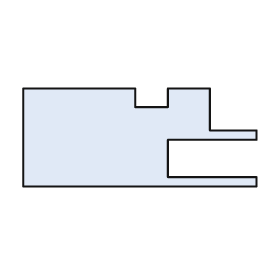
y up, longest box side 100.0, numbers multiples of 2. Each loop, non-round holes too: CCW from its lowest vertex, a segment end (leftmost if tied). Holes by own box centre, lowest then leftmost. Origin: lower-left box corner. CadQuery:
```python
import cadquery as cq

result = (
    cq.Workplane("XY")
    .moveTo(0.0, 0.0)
    .lineTo(100.0, 0.0)
    .lineTo(100.0, 4.0)
    .lineTo(62.0, 4.0)
    .lineTo(62.0, 20.0)
    .lineTo(100.0, 20.0)
    .lineTo(100.0, 24.0)
    .lineTo(80.0, 24.0)
    .lineTo(80.0, 42.0)
    .lineTo(62.0, 42.0)
    .lineTo(62.0, 34.0)
    .lineTo(48.0, 34.0)
    .lineTo(48.0, 42.0)
    .lineTo(0.0, 42.0)
    .close()
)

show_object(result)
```